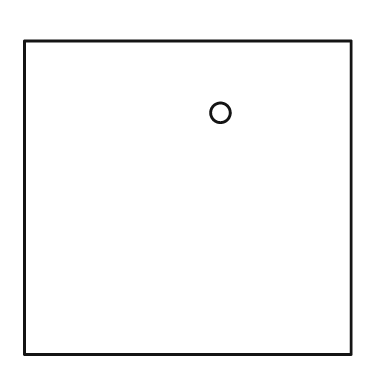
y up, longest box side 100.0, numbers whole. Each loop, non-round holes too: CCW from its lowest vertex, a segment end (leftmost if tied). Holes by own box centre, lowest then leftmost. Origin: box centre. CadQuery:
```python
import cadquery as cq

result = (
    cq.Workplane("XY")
    .moveTo(-50.0, -48.0)
    .lineTo(50.0, -48.0)
    .lineTo(50.0, 48.0)
    .lineTo(-50.0, 48.0)
    .close()
    .moveTo(10.0, 26.0)
    .circle(3.0)
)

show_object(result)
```